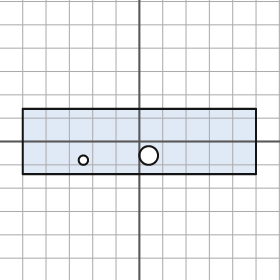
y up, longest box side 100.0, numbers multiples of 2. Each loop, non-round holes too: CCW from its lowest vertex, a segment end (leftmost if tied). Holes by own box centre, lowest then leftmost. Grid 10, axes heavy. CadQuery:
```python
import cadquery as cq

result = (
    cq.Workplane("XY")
    .moveTo(-50.0, -14.0)
    .lineTo(50.0, -14.0)
    .lineTo(50.0, 14.0)
    .lineTo(-50.0, 14.0)
    .close()
    .moveTo(-24.0, -8.0)
    .circle(2.0)
    .moveTo(4.0, -6.0)
    .circle(4.0)
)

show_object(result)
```